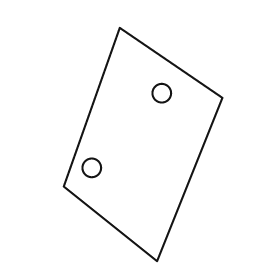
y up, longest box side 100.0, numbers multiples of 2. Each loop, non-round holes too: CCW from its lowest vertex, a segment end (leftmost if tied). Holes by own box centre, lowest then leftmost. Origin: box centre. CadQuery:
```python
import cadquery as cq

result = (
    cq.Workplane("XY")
    .moveTo(6.0, -50.0)
    .lineTo(34.0, 20.0)
    .lineTo(-10.0, 50.0)
    .lineTo(-34.0, -18.0)
    .close()
    .moveTo(-22.0, -10.0)
    .circle(4.0)
    .moveTo(8.0, 22.0)
    .circle(4.0)
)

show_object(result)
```